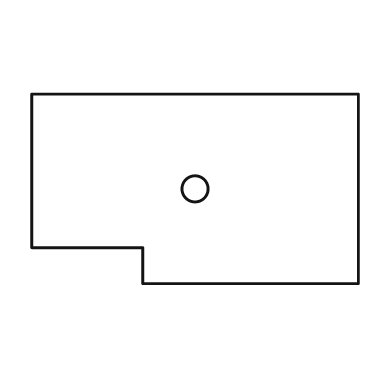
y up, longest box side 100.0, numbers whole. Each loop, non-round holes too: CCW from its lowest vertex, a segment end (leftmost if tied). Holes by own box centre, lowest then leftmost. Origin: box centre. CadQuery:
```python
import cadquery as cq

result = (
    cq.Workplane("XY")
    .moveTo(-16.0, -29.0)
    .lineTo(50.0, -29.0)
    .lineTo(50.0, 29.0)
    .lineTo(-50.0, 29.0)
    .lineTo(-50.0, -18.0)
    .lineTo(-16.0, -18.0)
    .close()
    .moveTo(0.0, 0.0)
    .circle(4.0)
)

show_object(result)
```